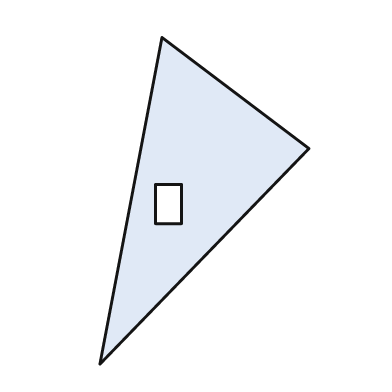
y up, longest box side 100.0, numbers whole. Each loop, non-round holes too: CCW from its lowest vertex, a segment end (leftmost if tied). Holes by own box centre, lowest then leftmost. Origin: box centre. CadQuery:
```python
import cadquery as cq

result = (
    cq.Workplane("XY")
    .moveTo(-32.0, -50.0)
    .lineTo(32.0, 16.0)
    .lineTo(-13.0, 50.0)
    .close()
    .moveTo(-15.0, -7.0)
    .lineTo(-7.0, -7.0)
    .lineTo(-7.0, 5.0)
    .lineTo(-15.0, 5.0)
    .close()
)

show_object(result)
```